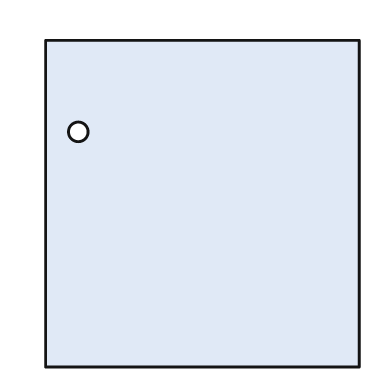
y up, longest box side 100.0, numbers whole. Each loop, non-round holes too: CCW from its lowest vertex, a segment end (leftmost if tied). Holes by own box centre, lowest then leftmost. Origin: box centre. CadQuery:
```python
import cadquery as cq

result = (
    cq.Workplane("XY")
    .moveTo(-48.0, -50.0)
    .lineTo(48.0, -50.0)
    .lineTo(48.0, 50.0)
    .lineTo(-48.0, 50.0)
    .close()
    .moveTo(-38.0, 22.0)
    .circle(3.0)
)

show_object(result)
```